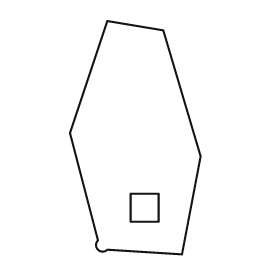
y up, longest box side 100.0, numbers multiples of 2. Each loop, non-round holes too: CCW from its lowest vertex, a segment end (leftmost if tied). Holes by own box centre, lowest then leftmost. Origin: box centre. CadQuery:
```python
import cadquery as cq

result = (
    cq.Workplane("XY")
    .moveTo(20.0, -50.0)
    .lineTo(28.0, -8.0)
    .lineTo(12.0, 46.0)
    .lineTo(-12.0, 50.0)
    .lineTo(-28.0, 2.0)
    .lineTo(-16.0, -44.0)
    .threePointArc((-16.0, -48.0), (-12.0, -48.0))
    .close()
    .moveTo(-2.0, -36.0)
    .lineTo(10.0, -36.0)
    .lineTo(10.0, -24.0)
    .lineTo(-2.0, -24.0)
    .close()
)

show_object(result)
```